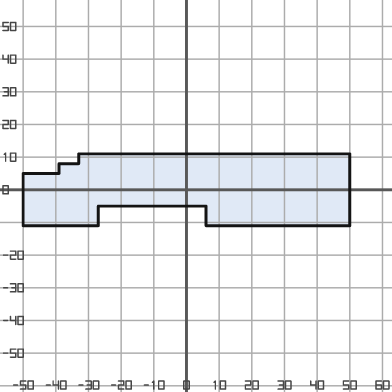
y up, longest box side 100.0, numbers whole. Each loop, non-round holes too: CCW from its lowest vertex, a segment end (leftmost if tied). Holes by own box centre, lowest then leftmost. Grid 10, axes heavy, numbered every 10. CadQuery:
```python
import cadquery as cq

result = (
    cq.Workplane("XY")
    .moveTo(-50.0, -11.0)
    .lineTo(-27.0, -11.0)
    .lineTo(-27.0, -5.0)
    .lineTo(6.0, -5.0)
    .lineTo(6.0, -11.0)
    .lineTo(50.0, -11.0)
    .lineTo(50.0, 11.0)
    .lineTo(-33.0, 11.0)
    .lineTo(-33.0, 8.0)
    .lineTo(-39.0, 8.0)
    .lineTo(-39.0, 5.0)
    .lineTo(-50.0, 5.0)
    .close()
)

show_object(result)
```